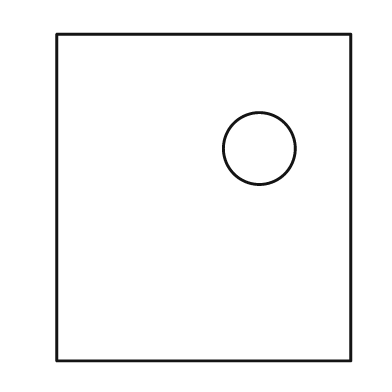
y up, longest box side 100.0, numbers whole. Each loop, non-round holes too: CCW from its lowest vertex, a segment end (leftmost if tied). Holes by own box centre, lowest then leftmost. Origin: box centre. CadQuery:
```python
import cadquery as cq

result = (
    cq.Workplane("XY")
    .moveTo(-45.0, -50.0)
    .lineTo(45.0, -50.0)
    .lineTo(45.0, 50.0)
    .lineTo(-45.0, 50.0)
    .close()
    .moveTo(17.0, 15.0)
    .circle(11.0)
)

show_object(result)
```